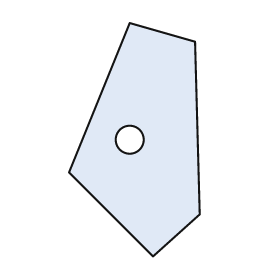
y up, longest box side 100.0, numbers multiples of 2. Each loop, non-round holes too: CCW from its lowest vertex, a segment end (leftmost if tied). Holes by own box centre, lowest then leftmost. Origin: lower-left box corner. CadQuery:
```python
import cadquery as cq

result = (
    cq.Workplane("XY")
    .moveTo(36.0, 0.0)
    .lineTo(56.0, 18.0)
    .lineTo(54.0, 92.0)
    .lineTo(26.0, 100.0)
    .lineTo(0.0, 36.0)
    .close()
    .moveTo(26.0, 50.0)
    .circle(6.0)
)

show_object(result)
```